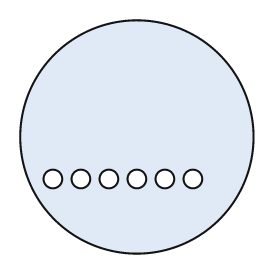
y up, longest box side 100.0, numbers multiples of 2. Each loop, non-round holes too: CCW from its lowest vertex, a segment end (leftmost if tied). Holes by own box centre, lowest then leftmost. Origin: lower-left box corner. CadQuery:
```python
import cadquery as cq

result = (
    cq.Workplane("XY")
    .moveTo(50.0, 50.0)
    .circle(50.0)
    .moveTo(14.0, 32.0)
    .circle(4.0)
    .moveTo(26.0, 32.0)
    .circle(4.0)
    .moveTo(38.0, 32.0)
    .circle(4.0)
    .moveTo(50.0, 32.0)
    .circle(4.0)
    .moveTo(62.0, 32.0)
    .circle(4.0)
    .moveTo(74.0, 32.0)
    .circle(4.0)
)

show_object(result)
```